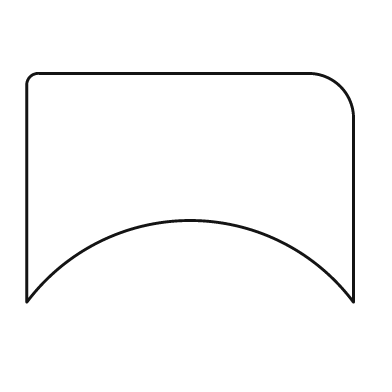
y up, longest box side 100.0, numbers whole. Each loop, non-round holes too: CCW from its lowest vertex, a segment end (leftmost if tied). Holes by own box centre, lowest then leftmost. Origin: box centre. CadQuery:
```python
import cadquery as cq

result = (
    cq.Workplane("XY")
    .moveTo(-50.0, -35.0)
    .threePointArc((0.0, -10.0), (50.0, -35.0))
    .lineTo(50.0, 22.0)
    .threePointArc((46.0, 31.0), (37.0, 35.0))
    .lineTo(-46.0, 35.0)
    .threePointArc((-49.0, 34.0), (-50.0, 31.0))
    .close()
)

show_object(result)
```